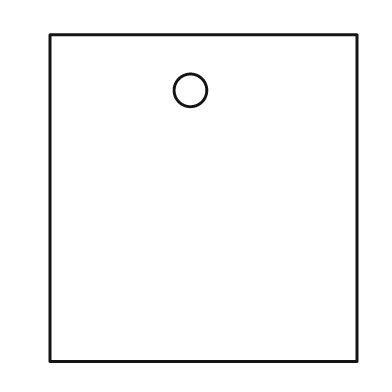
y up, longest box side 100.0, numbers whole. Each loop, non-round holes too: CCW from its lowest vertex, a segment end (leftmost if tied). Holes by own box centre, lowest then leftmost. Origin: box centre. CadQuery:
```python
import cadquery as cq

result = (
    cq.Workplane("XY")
    .moveTo(-47.0, -50.0)
    .lineTo(47.0, -50.0)
    .lineTo(47.0, 50.0)
    .lineTo(-47.0, 50.0)
    .close()
    .moveTo(-4.0, 33.0)
    .circle(5.0)
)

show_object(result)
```